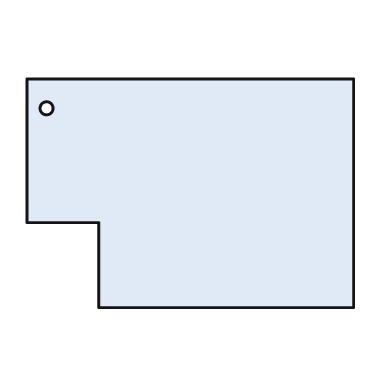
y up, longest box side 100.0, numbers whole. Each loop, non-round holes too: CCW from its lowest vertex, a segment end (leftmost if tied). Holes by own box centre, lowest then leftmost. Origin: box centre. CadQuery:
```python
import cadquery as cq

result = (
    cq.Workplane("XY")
    .moveTo(-28.0, -35.0)
    .lineTo(50.0, -35.0)
    .lineTo(50.0, 35.0)
    .lineTo(-50.0, 35.0)
    .lineTo(-50.0, -9.0)
    .lineTo(-28.0, -9.0)
    .close()
    .moveTo(-44.0, 26.0)
    .circle(2.0)
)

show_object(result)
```